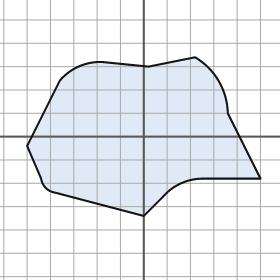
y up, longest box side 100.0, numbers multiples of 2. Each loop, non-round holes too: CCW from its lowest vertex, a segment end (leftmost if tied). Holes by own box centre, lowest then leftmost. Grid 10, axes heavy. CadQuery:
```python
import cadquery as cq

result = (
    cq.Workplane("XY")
    .moveTo(0.0, -34.0)
    .lineTo(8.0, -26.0)
    .threePointArc((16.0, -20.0), (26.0, -18.0))
    .lineTo(50.0, -18.0)
    .lineTo(36.0, 10.0)
    .threePointArc((32.0, 24.0), (22.0, 34.0))
    .lineTo(2.0, 30.0)
    .lineTo(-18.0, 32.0)
    .threePointArc((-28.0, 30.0), (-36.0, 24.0))
    .lineTo(-50.0, -4.0)
    .lineTo(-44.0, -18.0)
    .threePointArc((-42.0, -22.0), (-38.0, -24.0))
    .close()
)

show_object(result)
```